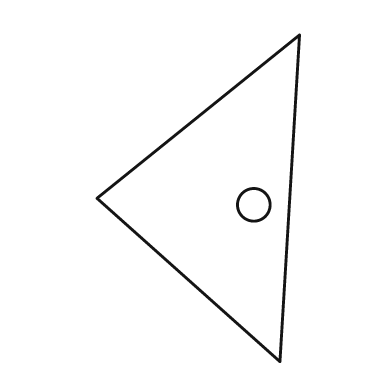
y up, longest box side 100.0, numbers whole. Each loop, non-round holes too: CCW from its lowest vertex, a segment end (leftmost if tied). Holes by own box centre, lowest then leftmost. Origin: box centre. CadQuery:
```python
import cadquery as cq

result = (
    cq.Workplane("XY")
    .moveTo(25.0, -50.0)
    .lineTo(31.0, 50.0)
    .lineTo(-31.0, 0.0)
    .close()
    .moveTo(17.0, -2.0)
    .circle(5.0)
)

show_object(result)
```